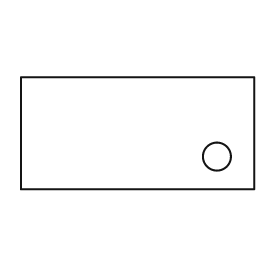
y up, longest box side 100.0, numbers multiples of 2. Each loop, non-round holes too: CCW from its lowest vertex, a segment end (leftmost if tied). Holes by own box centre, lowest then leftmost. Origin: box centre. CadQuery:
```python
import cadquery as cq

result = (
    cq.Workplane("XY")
    .moveTo(-50.0, -24.0)
    .lineTo(50.0, -24.0)
    .lineTo(50.0, 24.0)
    .lineTo(-50.0, 24.0)
    .close()
    .moveTo(34.0, -10.0)
    .circle(6.0)
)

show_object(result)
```